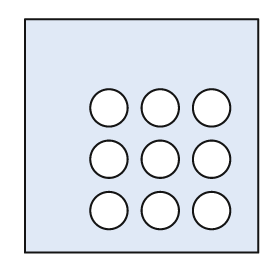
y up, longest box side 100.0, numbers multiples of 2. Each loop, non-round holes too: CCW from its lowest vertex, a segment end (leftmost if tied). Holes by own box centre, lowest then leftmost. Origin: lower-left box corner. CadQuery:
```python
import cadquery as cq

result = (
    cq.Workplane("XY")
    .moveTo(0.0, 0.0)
    .lineTo(100.0, 0.0)
    .lineTo(100.0, 100.0)
    .lineTo(0.0, 100.0)
    .close()
    .moveTo(36.0, 18.0)
    .circle(8.0)
    .moveTo(58.0, 18.0)
    .circle(8.0)
    .moveTo(80.0, 18.0)
    .circle(8.0)
    .moveTo(36.0, 40.0)
    .circle(8.0)
    .moveTo(58.0, 40.0)
    .circle(8.0)
    .moveTo(80.0, 40.0)
    .circle(8.0)
    .moveTo(36.0, 62.0)
    .circle(8.0)
    .moveTo(58.0, 62.0)
    .circle(8.0)
    .moveTo(80.0, 62.0)
    .circle(8.0)
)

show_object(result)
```